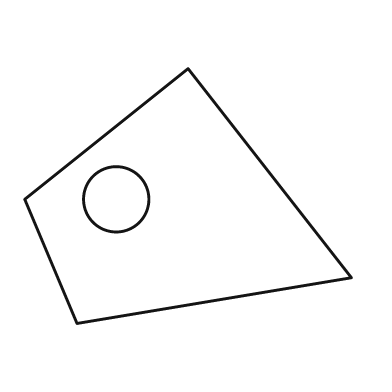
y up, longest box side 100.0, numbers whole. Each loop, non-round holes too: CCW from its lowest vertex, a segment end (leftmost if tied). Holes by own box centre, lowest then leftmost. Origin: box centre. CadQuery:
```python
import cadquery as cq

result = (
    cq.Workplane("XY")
    .moveTo(-34.0, -39.0)
    .lineTo(50.0, -25.0)
    .lineTo(0.0, 39.0)
    .lineTo(-50.0, -1.0)
    .close()
    .moveTo(-22.0, -1.0)
    .circle(10.0)
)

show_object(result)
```